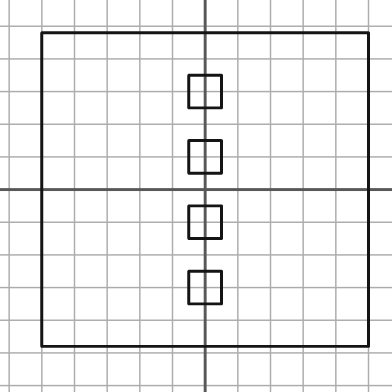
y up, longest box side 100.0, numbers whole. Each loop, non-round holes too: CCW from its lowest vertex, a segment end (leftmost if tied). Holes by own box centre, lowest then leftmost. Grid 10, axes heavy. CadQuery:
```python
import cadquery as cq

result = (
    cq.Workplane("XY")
    .moveTo(-50.0, -48.0)
    .lineTo(50.0, -48.0)
    .lineTo(50.0, 48.0)
    .lineTo(-50.0, 48.0)
    .close()
    .moveTo(-5.0, -35.0)
    .lineTo(5.0, -35.0)
    .lineTo(5.0, -25.0)
    .lineTo(-5.0, -25.0)
    .close()
    .moveTo(-5.0, -15.0)
    .lineTo(5.0, -15.0)
    .lineTo(5.0, -5.0)
    .lineTo(-5.0, -5.0)
    .close()
    .moveTo(-5.0, 5.0)
    .lineTo(5.0, 5.0)
    .lineTo(5.0, 15.0)
    .lineTo(-5.0, 15.0)
    .close()
    .moveTo(-5.0, 25.0)
    .lineTo(5.0, 25.0)
    .lineTo(5.0, 35.0)
    .lineTo(-5.0, 35.0)
    .close()
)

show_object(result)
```